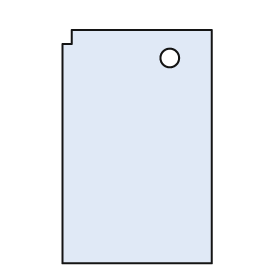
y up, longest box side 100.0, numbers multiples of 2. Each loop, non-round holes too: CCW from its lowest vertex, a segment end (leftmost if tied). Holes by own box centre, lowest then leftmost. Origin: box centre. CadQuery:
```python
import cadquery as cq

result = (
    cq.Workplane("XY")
    .moveTo(-32.0, -50.0)
    .lineTo(32.0, -50.0)
    .lineTo(32.0, 50.0)
    .lineTo(-28.0, 50.0)
    .lineTo(-28.0, 44.0)
    .lineTo(-32.0, 44.0)
    .close()
    .moveTo(14.0, 38.0)
    .circle(4.0)
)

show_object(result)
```